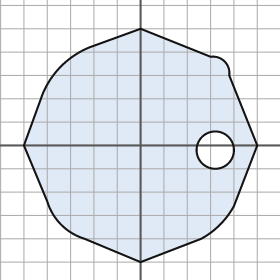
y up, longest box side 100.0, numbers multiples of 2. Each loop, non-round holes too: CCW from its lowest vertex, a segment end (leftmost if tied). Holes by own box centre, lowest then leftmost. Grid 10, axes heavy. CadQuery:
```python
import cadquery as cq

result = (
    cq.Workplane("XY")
    .moveTo(0.0, -50.0)
    .lineTo(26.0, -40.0)
    .threePointArc((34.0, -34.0), (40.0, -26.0))
    .lineTo(50.0, 0.0)
    .lineTo(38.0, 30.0)
    .threePointArc((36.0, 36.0), (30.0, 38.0))
    .lineTo(0.0, 50.0)
    .lineTo(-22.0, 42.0)
    .threePointArc((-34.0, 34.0), (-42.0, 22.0))
    .lineTo(-50.0, 0.0)
    .lineTo(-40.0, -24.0)
    .threePointArc((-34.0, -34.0), (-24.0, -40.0))
    .close()
    .moveTo(32.0, -2.0)
    .circle(8.0)
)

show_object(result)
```